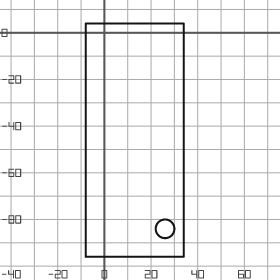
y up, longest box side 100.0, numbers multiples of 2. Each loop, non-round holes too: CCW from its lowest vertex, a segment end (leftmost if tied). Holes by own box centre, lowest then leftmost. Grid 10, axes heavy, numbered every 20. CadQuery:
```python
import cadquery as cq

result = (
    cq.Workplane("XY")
    .moveTo(-8.0, -96.0)
    .lineTo(34.0, -96.0)
    .lineTo(34.0, 4.0)
    .lineTo(-8.0, 4.0)
    .close()
    .moveTo(26.0, -84.0)
    .circle(4.0)
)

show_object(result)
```